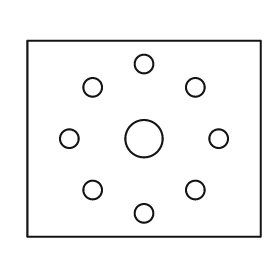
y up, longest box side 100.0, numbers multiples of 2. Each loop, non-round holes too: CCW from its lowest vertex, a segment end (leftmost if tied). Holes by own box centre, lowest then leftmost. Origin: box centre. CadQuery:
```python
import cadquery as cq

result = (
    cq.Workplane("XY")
    .moveTo(-50.0, -42.0)
    .lineTo(50.0, -42.0)
    .lineTo(50.0, 42.0)
    .lineTo(-50.0, 42.0)
    .close()
    .moveTo(0.0, -32.0)
    .circle(4.0)
    .moveTo(-22.0, -22.0)
    .circle(4.0)
    .moveTo(22.0, -22.0)
    .circle(4.0)
    .moveTo(-32.0, 0.0)
    .circle(4.0)
    .moveTo(0.0, 0.0)
    .circle(8.0)
    .moveTo(32.0, 0.0)
    .circle(4.0)
    .moveTo(-22.0, 22.0)
    .circle(4.0)
    .moveTo(22.0, 22.0)
    .circle(4.0)
    .moveTo(0.0, 32.0)
    .circle(4.0)
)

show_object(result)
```